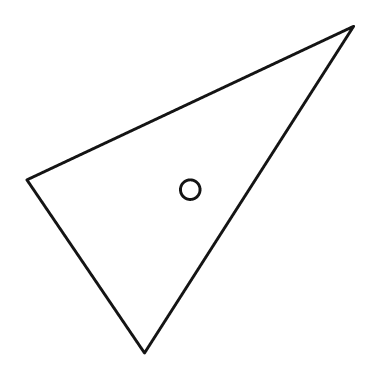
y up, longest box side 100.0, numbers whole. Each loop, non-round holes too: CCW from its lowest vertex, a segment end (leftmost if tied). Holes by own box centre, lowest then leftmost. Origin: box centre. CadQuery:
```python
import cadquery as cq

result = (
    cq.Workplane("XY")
    .moveTo(-14.0, -50.0)
    .lineTo(50.0, 50.0)
    .lineTo(-50.0, 3.0)
    .close()
    .moveTo(0.0, 0.0)
    .circle(3.0)
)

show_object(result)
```